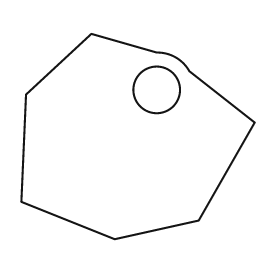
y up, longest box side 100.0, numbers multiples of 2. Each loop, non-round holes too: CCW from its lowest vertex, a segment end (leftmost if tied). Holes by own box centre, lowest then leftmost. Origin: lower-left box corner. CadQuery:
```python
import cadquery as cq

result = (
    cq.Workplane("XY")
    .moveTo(40.0, 0.0)
    .lineTo(76.0, 8.0)
    .lineTo(100.0, 50.0)
    .lineTo(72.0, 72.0)
    .threePointArc((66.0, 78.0), (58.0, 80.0))
    .lineTo(30.0, 88.0)
    .lineTo(2.0, 62.0)
    .lineTo(0.0, 16.0)
    .close()
    .moveTo(58.0, 64.0)
    .circle(10.0)
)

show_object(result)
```